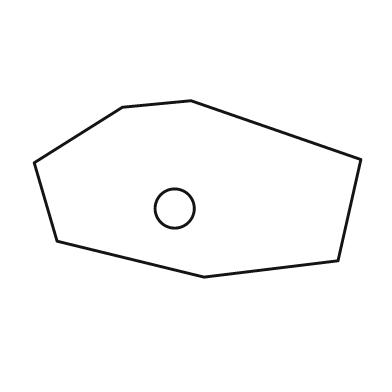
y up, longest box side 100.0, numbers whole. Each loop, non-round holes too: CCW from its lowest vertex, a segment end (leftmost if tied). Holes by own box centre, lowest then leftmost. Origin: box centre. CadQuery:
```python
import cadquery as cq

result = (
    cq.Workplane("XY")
    .moveTo(2.0, -27.0)
    .lineTo(43.0, -22.0)
    .lineTo(50.0, 9.0)
    .lineTo(-2.0, 27.0)
    .lineTo(-23.0, 25.0)
    .lineTo(-50.0, 8.0)
    .lineTo(-43.0, -16.0)
    .close()
    .moveTo(-7.0, -6.0)
    .circle(6.0)
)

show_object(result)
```